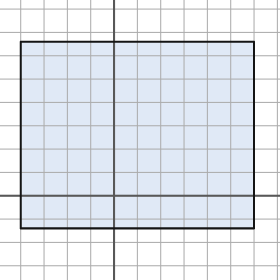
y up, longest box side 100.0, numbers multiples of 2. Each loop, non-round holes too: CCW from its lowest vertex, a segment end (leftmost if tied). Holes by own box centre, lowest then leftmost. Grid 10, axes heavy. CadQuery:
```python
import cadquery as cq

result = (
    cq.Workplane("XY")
    .moveTo(-40.0, -14.0)
    .lineTo(60.0, -14.0)
    .lineTo(60.0, 66.0)
    .lineTo(-40.0, 66.0)
    .close()
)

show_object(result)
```